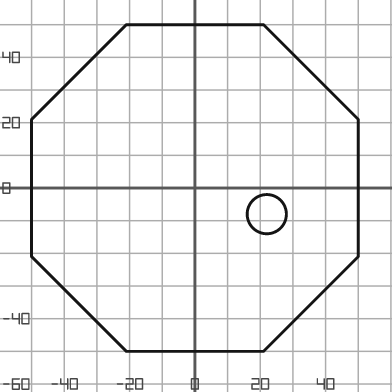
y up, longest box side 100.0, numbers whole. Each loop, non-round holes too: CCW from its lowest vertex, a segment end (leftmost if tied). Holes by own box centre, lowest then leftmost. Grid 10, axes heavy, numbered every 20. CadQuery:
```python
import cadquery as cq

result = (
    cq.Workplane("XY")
    .moveTo(-21.0, -50.0)
    .lineTo(21.0, -50.0)
    .lineTo(50.0, -21.0)
    .lineTo(50.0, 21.0)
    .lineTo(21.0, 50.0)
    .lineTo(-21.0, 50.0)
    .lineTo(-50.0, 21.0)
    .lineTo(-50.0, -21.0)
    .close()
    .moveTo(22.0, -8.0)
    .circle(6.0)
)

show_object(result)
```